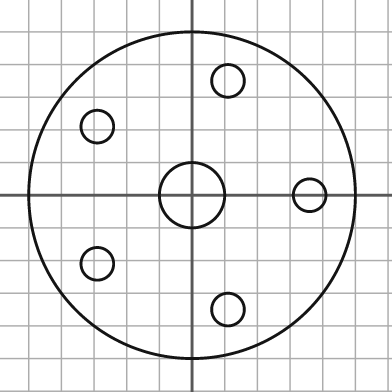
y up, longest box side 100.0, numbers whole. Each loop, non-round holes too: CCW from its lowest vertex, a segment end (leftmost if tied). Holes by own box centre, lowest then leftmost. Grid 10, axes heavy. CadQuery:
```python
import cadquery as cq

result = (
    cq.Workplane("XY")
    .moveTo(0.0, 0.0)
    .circle(50.0)
    .moveTo(11.0, -35.0)
    .circle(5.0)
    .moveTo(-29.0, -21.0)
    .circle(5.0)
    .moveTo(0.0, 0.0)
    .circle(10.0)
    .moveTo(36.0, 0.0)
    .circle(5.0)
    .moveTo(-29.0, 21.0)
    .circle(5.0)
    .moveTo(11.0, 35.0)
    .circle(5.0)
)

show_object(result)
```